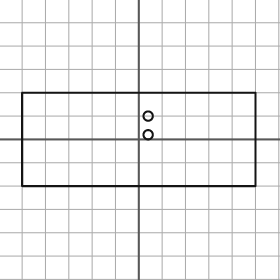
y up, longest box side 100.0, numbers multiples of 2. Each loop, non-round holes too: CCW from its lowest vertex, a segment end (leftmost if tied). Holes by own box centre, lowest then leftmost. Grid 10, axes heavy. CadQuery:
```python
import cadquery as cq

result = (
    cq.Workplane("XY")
    .moveTo(-50.0, -20.0)
    .lineTo(50.0, -20.0)
    .lineTo(50.0, 20.0)
    .lineTo(-50.0, 20.0)
    .close()
    .moveTo(4.0, 2.0)
    .circle(2.0)
    .moveTo(4.0, 10.0)
    .circle(2.0)
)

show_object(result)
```